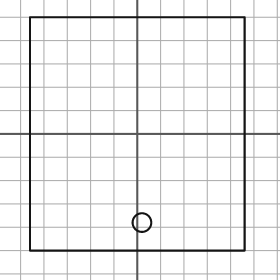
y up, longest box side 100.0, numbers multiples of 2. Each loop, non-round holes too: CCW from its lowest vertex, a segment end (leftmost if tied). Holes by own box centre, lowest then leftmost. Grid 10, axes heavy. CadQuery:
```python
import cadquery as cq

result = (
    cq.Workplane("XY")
    .moveTo(-46.0, -50.0)
    .lineTo(46.0, -50.0)
    .lineTo(46.0, 50.0)
    .lineTo(-46.0, 50.0)
    .close()
    .moveTo(2.0, -38.0)
    .circle(4.0)
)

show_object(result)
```